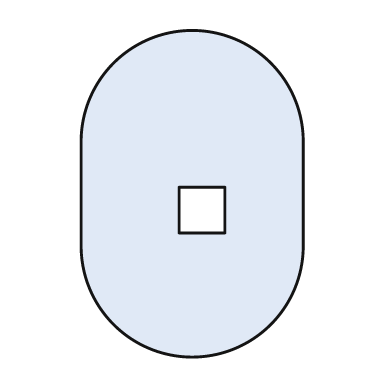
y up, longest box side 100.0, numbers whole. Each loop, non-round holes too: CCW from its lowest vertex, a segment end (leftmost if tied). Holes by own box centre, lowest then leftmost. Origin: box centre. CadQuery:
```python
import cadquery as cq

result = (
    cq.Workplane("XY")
    .moveTo(-34.0, -16.0)
    .threePointArc((0.0, -50.0), (34.0, -16.0))
    .lineTo(34.0, 16.0)
    .threePointArc((0.0, 50.0), (-34.0, 16.0))
    .close()
    .moveTo(-4.0, -12.0)
    .lineTo(10.0, -12.0)
    .lineTo(10.0, 2.0)
    .lineTo(-4.0, 2.0)
    .close()
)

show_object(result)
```